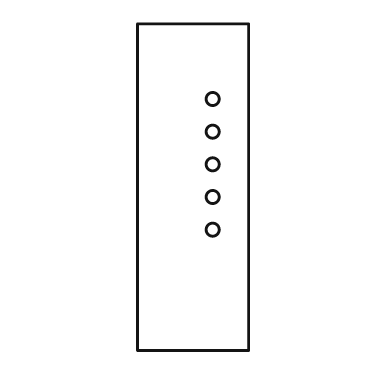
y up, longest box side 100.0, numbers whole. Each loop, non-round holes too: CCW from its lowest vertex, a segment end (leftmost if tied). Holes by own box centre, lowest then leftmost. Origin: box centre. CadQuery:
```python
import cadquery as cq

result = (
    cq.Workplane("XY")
    .moveTo(-17.0, -50.0)
    .lineTo(17.0, -50.0)
    .lineTo(17.0, 50.0)
    .lineTo(-17.0, 50.0)
    .close()
    .moveTo(6.0, -13.0)
    .circle(2.0)
    .moveTo(6.0, -3.0)
    .circle(2.0)
    .moveTo(6.0, 7.0)
    .circle(2.0)
    .moveTo(6.0, 17.0)
    .circle(2.0)
    .moveTo(6.0, 27.0)
    .circle(2.0)
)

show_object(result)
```